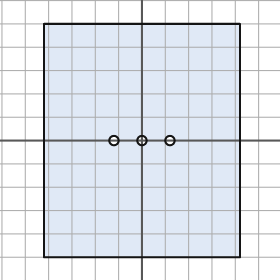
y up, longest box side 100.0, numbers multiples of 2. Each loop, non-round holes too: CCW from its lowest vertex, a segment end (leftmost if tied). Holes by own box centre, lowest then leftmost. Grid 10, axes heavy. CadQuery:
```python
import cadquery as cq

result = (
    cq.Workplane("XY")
    .moveTo(-42.0, -50.0)
    .lineTo(42.0, -50.0)
    .lineTo(42.0, 50.0)
    .lineTo(-42.0, 50.0)
    .close()
    .moveTo(-12.0, 0.0)
    .circle(2.0)
    .moveTo(0.0, 0.0)
    .circle(2.0)
    .moveTo(12.0, 0.0)
    .circle(2.0)
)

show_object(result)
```